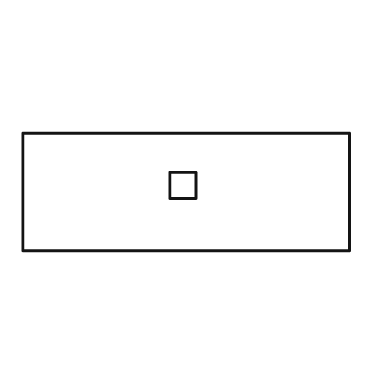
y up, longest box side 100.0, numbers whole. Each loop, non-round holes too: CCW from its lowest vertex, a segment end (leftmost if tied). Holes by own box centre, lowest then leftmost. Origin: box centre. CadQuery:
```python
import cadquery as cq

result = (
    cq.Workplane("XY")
    .moveTo(-50.0, -18.0)
    .lineTo(50.0, -18.0)
    .lineTo(50.0, 18.0)
    .lineTo(-50.0, 18.0)
    .close()
    .moveTo(-5.0, -2.0)
    .lineTo(3.0, -2.0)
    .lineTo(3.0, 6.0)
    .lineTo(-5.0, 6.0)
    .close()
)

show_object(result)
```